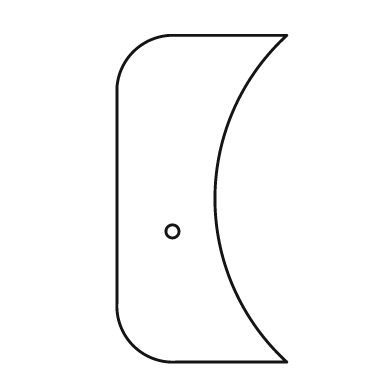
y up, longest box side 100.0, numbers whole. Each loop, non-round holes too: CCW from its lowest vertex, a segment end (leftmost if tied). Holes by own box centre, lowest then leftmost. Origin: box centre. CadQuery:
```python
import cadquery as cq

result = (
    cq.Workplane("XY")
    .moveTo(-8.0, -50.0)
    .lineTo(26.0, -50.0)
    .threePointArc((4.0, 0.0), (26.0, 50.0))
    .lineTo(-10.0, 50.0)
    .threePointArc((-21.0, 45.0), (-26.0, 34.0))
    .lineTo(-26.0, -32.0)
    .threePointArc((-21.0, -45.0), (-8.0, -50.0))
    .close()
    .moveTo(-9.0, -10.0)
    .circle(2.0)
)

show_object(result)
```